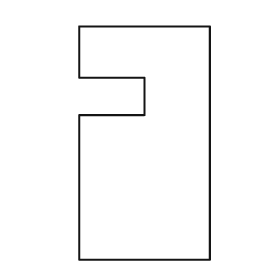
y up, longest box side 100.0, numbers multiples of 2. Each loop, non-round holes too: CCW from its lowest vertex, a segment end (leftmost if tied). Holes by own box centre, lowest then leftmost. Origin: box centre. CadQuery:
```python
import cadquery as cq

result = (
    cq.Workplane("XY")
    .moveTo(-28.0, -50.0)
    .lineTo(28.0, -50.0)
    .lineTo(28.0, 50.0)
    .lineTo(-28.0, 50.0)
    .lineTo(-28.0, 28.0)
    .lineTo(0.0, 28.0)
    .lineTo(0.0, 12.0)
    .lineTo(-28.0, 12.0)
    .close()
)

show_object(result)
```